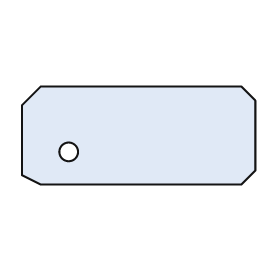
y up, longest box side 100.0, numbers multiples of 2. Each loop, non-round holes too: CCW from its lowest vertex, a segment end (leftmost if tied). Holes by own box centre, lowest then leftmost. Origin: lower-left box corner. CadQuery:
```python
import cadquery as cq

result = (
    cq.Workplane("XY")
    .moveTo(8.0, 0.0)
    .lineTo(94.0, 0.0)
    .lineTo(100.0, 6.0)
    .lineTo(100.0, 36.0)
    .lineTo(94.0, 42.0)
    .lineTo(8.0, 42.0)
    .lineTo(0.0, 34.0)
    .lineTo(0.0, 4.0)
    .close()
    .moveTo(20.0, 14.0)
    .circle(4.0)
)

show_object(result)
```